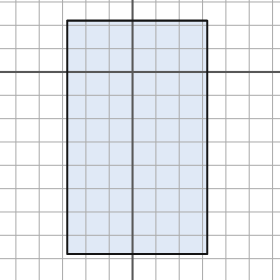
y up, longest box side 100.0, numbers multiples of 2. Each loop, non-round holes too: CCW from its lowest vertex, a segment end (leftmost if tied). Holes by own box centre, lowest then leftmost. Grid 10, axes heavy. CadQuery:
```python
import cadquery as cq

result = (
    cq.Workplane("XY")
    .moveTo(-28.0, -78.0)
    .lineTo(32.0, -78.0)
    .lineTo(32.0, 22.0)
    .lineTo(-28.0, 22.0)
    .close()
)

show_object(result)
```